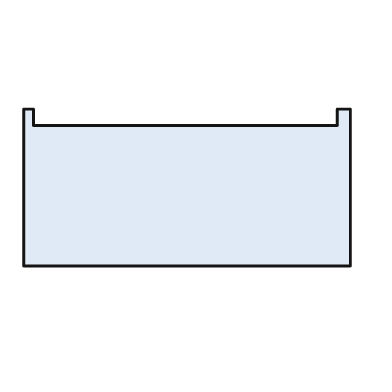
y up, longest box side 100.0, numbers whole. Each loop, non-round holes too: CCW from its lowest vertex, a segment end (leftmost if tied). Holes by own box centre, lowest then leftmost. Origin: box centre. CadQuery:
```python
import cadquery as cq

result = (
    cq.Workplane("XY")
    .moveTo(-50.0, -24.0)
    .lineTo(50.0, -24.0)
    .lineTo(50.0, 24.0)
    .lineTo(46.0, 24.0)
    .lineTo(46.0, 19.0)
    .lineTo(-47.0, 19.0)
    .lineTo(-47.0, 24.0)
    .lineTo(-50.0, 24.0)
    .close()
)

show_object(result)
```